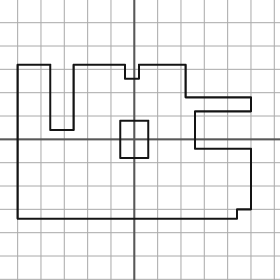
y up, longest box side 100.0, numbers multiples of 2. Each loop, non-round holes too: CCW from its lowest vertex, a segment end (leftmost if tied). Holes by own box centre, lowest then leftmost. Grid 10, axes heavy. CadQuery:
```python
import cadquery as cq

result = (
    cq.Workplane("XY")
    .moveTo(-50.0, -34.0)
    .lineTo(44.0, -34.0)
    .lineTo(44.0, -30.0)
    .lineTo(50.0, -30.0)
    .lineTo(50.0, -4.0)
    .lineTo(26.0, -4.0)
    .lineTo(26.0, 12.0)
    .lineTo(50.0, 12.0)
    .lineTo(50.0, 18.0)
    .lineTo(22.0, 18.0)
    .lineTo(22.0, 32.0)
    .lineTo(2.0, 32.0)
    .lineTo(2.0, 26.0)
    .lineTo(-4.0, 26.0)
    .lineTo(-4.0, 32.0)
    .lineTo(-26.0, 32.0)
    .lineTo(-26.0, 4.0)
    .lineTo(-36.0, 4.0)
    .lineTo(-36.0, 32.0)
    .lineTo(-50.0, 32.0)
    .close()
    .moveTo(-6.0, -8.0)
    .lineTo(6.0, -8.0)
    .lineTo(6.0, 8.0)
    .lineTo(-6.0, 8.0)
    .close()
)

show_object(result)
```